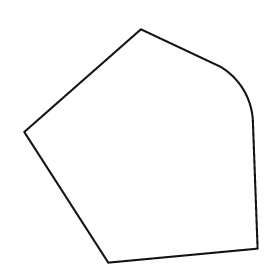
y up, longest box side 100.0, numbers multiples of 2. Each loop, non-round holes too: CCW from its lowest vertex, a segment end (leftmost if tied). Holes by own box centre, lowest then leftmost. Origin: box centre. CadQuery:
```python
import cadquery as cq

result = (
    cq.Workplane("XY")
    .moveTo(-14.0, -50.0)
    .lineTo(50.0, -44.0)
    .lineTo(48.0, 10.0)
    .threePointArc((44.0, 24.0), (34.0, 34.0))
    .lineTo(0.0, 50.0)
    .lineTo(-50.0, 6.0)
    .close()
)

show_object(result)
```